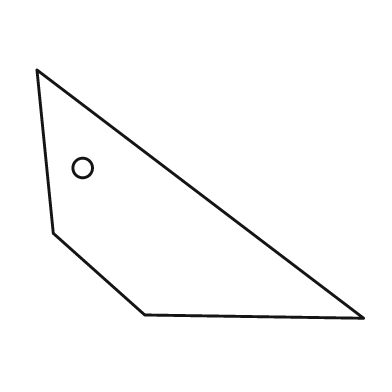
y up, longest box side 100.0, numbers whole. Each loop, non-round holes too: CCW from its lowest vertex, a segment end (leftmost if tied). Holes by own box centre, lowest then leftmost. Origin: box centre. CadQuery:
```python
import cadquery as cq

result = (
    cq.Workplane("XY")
    .moveTo(50.0, -38.0)
    .lineTo(-50.0, 38.0)
    .lineTo(-45.0, -12.0)
    .lineTo(-17.0, -37.0)
    .close()
    .moveTo(-36.0, 8.0)
    .circle(3.0)
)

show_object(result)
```